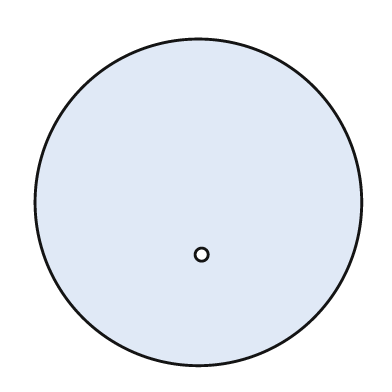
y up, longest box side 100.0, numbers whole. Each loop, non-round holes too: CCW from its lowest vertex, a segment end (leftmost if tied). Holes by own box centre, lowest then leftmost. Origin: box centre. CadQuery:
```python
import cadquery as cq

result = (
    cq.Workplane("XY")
    .moveTo(0.0, 0.0)
    .circle(50.0)
    .moveTo(1.0, -16.0)
    .circle(2.0)
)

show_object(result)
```